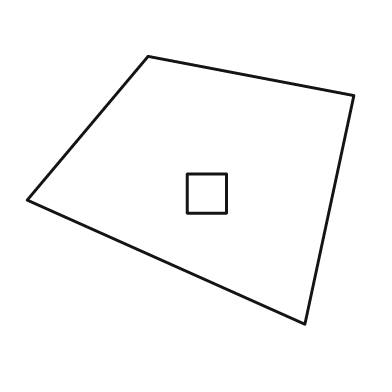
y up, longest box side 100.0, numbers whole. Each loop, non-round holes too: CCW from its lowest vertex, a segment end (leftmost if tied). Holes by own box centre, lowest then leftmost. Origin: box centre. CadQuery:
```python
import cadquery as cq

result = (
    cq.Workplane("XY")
    .moveTo(35.0, -41.0)
    .lineTo(50.0, 29.0)
    .lineTo(-13.0, 41.0)
    .lineTo(-50.0, -3.0)
    .close()
    .moveTo(-1.0, -7.0)
    .lineTo(11.0, -7.0)
    .lineTo(11.0, 5.0)
    .lineTo(-1.0, 5.0)
    .close()
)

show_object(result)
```